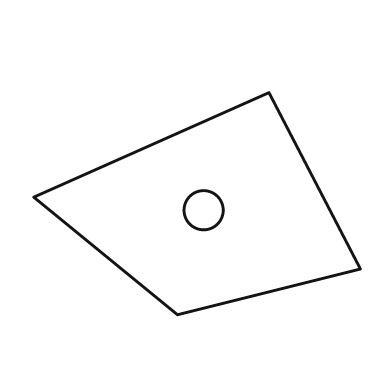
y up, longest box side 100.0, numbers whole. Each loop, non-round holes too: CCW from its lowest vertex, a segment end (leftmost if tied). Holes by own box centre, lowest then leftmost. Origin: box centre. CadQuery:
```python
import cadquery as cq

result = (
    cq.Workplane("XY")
    .moveTo(-6.0, -34.0)
    .lineTo(50.0, -20.0)
    .lineTo(22.0, 34.0)
    .lineTo(-50.0, 2.0)
    .close()
    .moveTo(2.0, -2.0)
    .circle(6.0)
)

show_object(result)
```